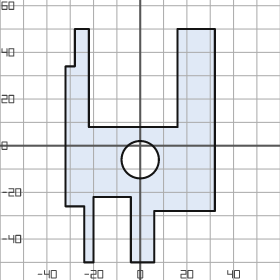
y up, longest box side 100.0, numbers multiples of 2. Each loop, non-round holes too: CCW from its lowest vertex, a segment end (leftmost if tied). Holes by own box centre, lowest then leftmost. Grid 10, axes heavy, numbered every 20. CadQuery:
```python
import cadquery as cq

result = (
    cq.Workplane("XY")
    .moveTo(-24.0, -50.0)
    .lineTo(-20.0, -50.0)
    .lineTo(-20.0, -22.0)
    .lineTo(-4.0, -22.0)
    .lineTo(-4.0, -50.0)
    .lineTo(6.0, -50.0)
    .lineTo(6.0, -28.0)
    .lineTo(32.0, -28.0)
    .lineTo(32.0, 50.0)
    .lineTo(16.0, 50.0)
    .lineTo(16.0, 8.0)
    .lineTo(-22.0, 8.0)
    .lineTo(-22.0, 50.0)
    .lineTo(-28.0, 50.0)
    .lineTo(-28.0, 34.0)
    .lineTo(-32.0, 34.0)
    .lineTo(-32.0, -26.0)
    .lineTo(-24.0, -26.0)
    .close()
    .moveTo(0.0, -6.0)
    .circle(8.0)
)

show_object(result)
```